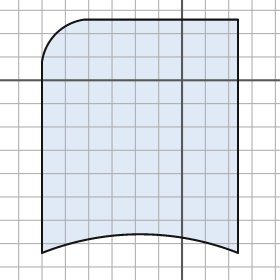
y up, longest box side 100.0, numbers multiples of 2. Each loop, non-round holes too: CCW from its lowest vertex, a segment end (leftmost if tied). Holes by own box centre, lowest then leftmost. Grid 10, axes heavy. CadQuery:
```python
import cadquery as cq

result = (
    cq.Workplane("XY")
    .moveTo(-60.0, -74.0)
    .threePointArc((-18.0, -66.0), (24.0, -74.0))
    .lineTo(24.0, 26.0)
    .lineTo(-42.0, 26.0)
    .threePointArc((-54.0, 20.0), (-60.0, 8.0))
    .close()
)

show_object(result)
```